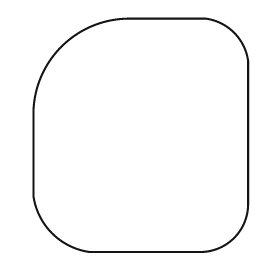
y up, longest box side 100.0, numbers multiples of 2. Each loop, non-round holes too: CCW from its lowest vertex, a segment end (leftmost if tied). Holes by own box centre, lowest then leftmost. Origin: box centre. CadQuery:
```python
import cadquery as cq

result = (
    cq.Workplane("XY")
    .moveTo(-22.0, -50.0)
    .lineTo(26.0, -50.0)
    .threePointArc((40.0, -44.0), (46.0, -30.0))
    .lineTo(46.0, 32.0)
    .threePointArc((40.0, 44.0), (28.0, 50.0))
    .lineTo(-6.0, 50.0)
    .threePointArc((-34.0, 38.0), (-46.0, 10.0))
    .lineTo(-46.0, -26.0)
    .threePointArc((-38.0, -42.0), (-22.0, -50.0))
    .close()
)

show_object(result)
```